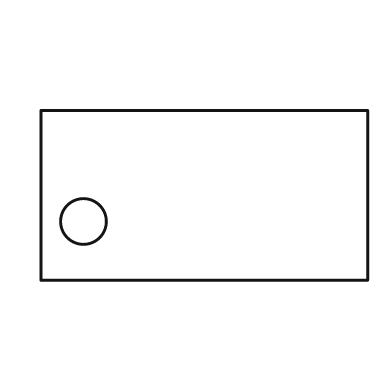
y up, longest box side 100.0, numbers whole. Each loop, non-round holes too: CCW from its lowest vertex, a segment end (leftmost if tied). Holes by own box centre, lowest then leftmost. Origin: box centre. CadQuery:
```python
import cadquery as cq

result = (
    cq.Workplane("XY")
    .moveTo(-50.0, -26.0)
    .lineTo(50.0, -26.0)
    .lineTo(50.0, 26.0)
    .lineTo(-50.0, 26.0)
    .close()
    .moveTo(-37.0, -8.0)
    .circle(7.0)
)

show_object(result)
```